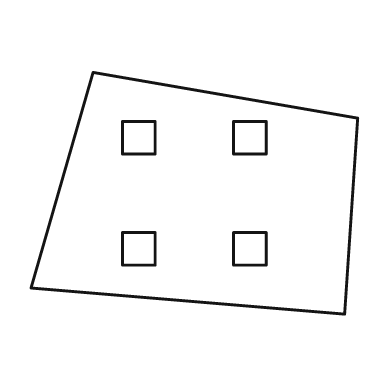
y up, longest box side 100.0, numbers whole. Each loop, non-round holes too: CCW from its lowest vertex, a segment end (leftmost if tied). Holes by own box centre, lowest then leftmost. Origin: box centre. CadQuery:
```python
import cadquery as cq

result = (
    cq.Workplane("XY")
    .moveTo(46.0, -37.0)
    .lineTo(50.0, 23.0)
    .lineTo(-31.0, 37.0)
    .lineTo(-50.0, -29.0)
    .close()
    .moveTo(-22.0, -22.0)
    .lineTo(-12.0, -22.0)
    .lineTo(-12.0, -12.0)
    .lineTo(-22.0, -12.0)
    .close()
    .moveTo(12.0, -22.0)
    .lineTo(22.0, -22.0)
    .lineTo(22.0, -12.0)
    .lineTo(12.0, -12.0)
    .close()
    .moveTo(-22.0, 12.0)
    .lineTo(-12.0, 12.0)
    .lineTo(-12.0, 22.0)
    .lineTo(-22.0, 22.0)
    .close()
    .moveTo(12.0, 12.0)
    .lineTo(22.0, 12.0)
    .lineTo(22.0, 22.0)
    .lineTo(12.0, 22.0)
    .close()
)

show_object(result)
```